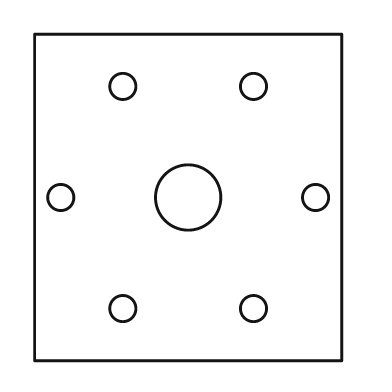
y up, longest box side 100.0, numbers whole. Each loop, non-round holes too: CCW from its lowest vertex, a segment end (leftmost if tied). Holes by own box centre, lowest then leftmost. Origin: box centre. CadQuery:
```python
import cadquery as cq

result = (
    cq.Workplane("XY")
    .moveTo(-47.0, -50.0)
    .lineTo(47.0, -50.0)
    .lineTo(47.0, 50.0)
    .lineTo(-47.0, 50.0)
    .close()
    .moveTo(-20.0, -34.0)
    .circle(4.0)
    .moveTo(20.0, -34.0)
    .circle(4.0)
    .moveTo(-39.0, 0.0)
    .circle(4.0)
    .moveTo(0.0, 0.0)
    .circle(10.0)
    .moveTo(39.0, 0.0)
    .circle(4.0)
    .moveTo(-20.0, 34.0)
    .circle(4.0)
    .moveTo(20.0, 34.0)
    .circle(4.0)
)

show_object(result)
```